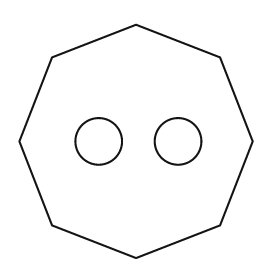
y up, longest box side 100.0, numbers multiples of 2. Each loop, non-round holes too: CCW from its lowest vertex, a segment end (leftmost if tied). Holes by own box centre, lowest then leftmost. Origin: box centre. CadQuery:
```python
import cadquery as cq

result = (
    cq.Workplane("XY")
    .moveTo(0.0, -50.0)
    .lineTo(36.0, -36.0)
    .lineTo(50.0, 0.0)
    .lineTo(36.0, 36.0)
    .lineTo(0.0, 50.0)
    .lineTo(-36.0, 36.0)
    .lineTo(-50.0, 0.0)
    .lineTo(-36.0, -36.0)
    .close()
    .moveTo(-16.0, 0.0)
    .circle(10.0)
    .moveTo(18.0, 0.0)
    .circle(10.0)
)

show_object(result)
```